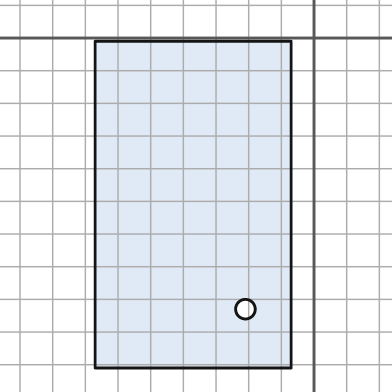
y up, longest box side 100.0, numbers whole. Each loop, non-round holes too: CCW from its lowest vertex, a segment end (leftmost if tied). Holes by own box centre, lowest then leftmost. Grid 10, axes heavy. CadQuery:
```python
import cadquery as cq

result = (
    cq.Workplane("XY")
    .moveTo(-67.0, -101.0)
    .lineTo(-7.0, -101.0)
    .lineTo(-7.0, -1.0)
    .lineTo(-67.0, -1.0)
    .close()
    .moveTo(-21.0, -83.0)
    .circle(3.0)
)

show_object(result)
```